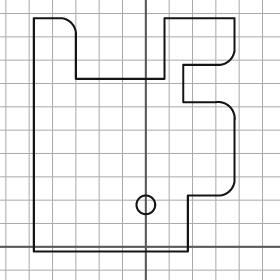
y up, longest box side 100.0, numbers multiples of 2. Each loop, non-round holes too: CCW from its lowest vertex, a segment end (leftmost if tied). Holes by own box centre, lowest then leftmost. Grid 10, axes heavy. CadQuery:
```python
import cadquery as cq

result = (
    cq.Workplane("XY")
    .moveTo(-48.0, -2.0)
    .lineTo(18.0, -2.0)
    .lineTo(18.0, 22.0)
    .lineTo(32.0, 22.0)
    .threePointArc((36.0, 24.0), (38.0, 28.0))
    .lineTo(38.0, 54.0)
    .threePointArc((36.0, 60.0), (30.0, 62.0))
    .lineTo(16.0, 62.0)
    .lineTo(16.0, 78.0)
    .lineTo(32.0, 78.0)
    .threePointArc((36.0, 80.0), (38.0, 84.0))
    .lineTo(38.0, 98.0)
    .lineTo(8.0, 98.0)
    .lineTo(8.0, 72.0)
    .lineTo(-30.0, 72.0)
    .lineTo(-30.0, 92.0)
    .threePointArc((-32.0, 96.0), (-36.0, 98.0))
    .lineTo(-48.0, 98.0)
    .close()
    .moveTo(0.0, 18.0)
    .circle(4.0)
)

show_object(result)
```